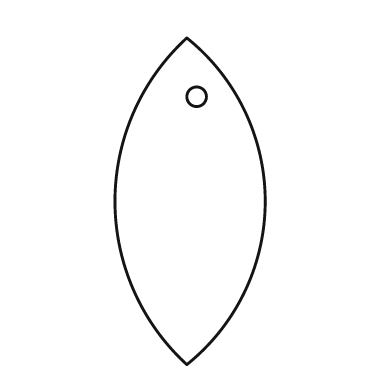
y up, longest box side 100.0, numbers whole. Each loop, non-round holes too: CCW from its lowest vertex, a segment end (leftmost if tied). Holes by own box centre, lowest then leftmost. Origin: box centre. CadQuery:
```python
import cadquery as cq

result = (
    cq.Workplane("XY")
    .moveTo(-1.0, -50.0)
    .threePointArc((23.0, 0.0), (-1.0, 50.0))
    .threePointArc((-23.0, 0.0), (-1.0, -50.0))
    .close()
    .moveTo(2.0, 32.0)
    .circle(3.0)
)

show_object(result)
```